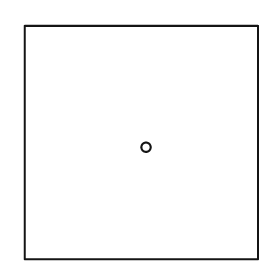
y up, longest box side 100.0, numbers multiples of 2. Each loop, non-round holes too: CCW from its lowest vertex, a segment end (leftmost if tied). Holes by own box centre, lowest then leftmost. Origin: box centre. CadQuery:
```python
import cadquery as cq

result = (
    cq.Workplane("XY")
    .moveTo(-50.0, -50.0)
    .lineTo(50.0, -50.0)
    .lineTo(50.0, 50.0)
    .lineTo(-50.0, 50.0)
    .close()
    .moveTo(2.0, -2.0)
    .circle(2.0)
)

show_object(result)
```